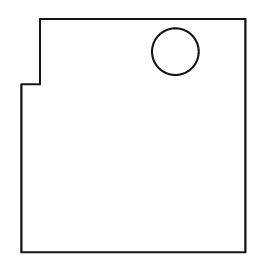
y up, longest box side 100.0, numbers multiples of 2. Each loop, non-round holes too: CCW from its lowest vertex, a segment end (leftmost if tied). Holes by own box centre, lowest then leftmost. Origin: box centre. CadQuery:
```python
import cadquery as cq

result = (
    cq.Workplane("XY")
    .moveTo(-48.0, -50.0)
    .lineTo(48.0, -50.0)
    .lineTo(48.0, 50.0)
    .lineTo(-40.0, 50.0)
    .lineTo(-40.0, 22.0)
    .lineTo(-48.0, 22.0)
    .close()
    .moveTo(18.0, 36.0)
    .circle(10.0)
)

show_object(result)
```